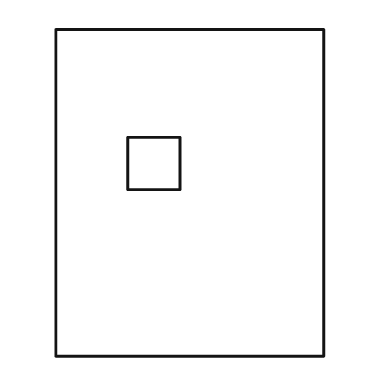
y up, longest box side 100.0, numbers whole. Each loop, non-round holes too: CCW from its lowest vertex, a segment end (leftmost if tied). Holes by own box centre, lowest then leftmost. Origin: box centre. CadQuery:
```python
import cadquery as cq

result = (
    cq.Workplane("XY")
    .moveTo(-41.0, -50.0)
    .lineTo(41.0, -50.0)
    .lineTo(41.0, 50.0)
    .lineTo(-41.0, 50.0)
    .close()
    .moveTo(-19.0, 1.0)
    .lineTo(-3.0, 1.0)
    .lineTo(-3.0, 17.0)
    .lineTo(-19.0, 17.0)
    .close()
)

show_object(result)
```